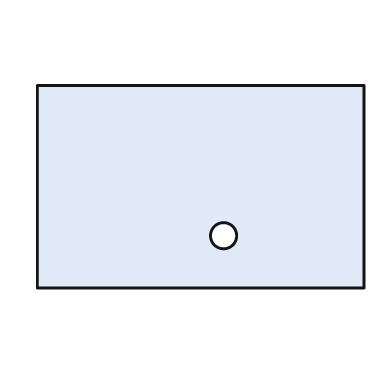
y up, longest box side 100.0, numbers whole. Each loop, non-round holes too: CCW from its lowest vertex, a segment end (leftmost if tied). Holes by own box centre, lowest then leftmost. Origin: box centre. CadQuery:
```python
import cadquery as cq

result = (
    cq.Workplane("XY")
    .moveTo(-50.0, -31.0)
    .lineTo(50.0, -31.0)
    .lineTo(50.0, 31.0)
    .lineTo(-50.0, 31.0)
    .close()
    .moveTo(7.0, -15.0)
    .circle(4.0)
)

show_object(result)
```